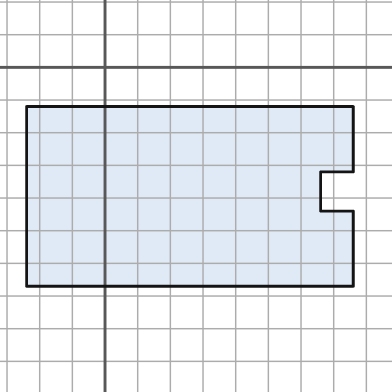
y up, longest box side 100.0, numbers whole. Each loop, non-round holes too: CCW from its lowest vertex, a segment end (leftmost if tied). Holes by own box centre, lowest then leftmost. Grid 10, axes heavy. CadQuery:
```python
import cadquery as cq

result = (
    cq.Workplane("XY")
    .moveTo(-24.0, -67.0)
    .lineTo(76.0, -67.0)
    .lineTo(76.0, -44.0)
    .lineTo(66.0, -44.0)
    .lineTo(66.0, -32.0)
    .lineTo(76.0, -32.0)
    .lineTo(76.0, -12.0)
    .lineTo(-24.0, -12.0)
    .close()
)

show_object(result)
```